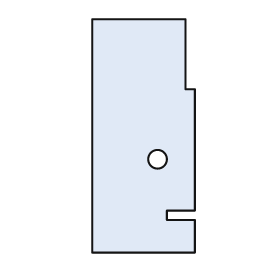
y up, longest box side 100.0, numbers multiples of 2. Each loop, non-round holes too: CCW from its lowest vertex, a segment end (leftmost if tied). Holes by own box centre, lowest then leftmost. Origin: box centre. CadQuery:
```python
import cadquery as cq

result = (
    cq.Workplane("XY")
    .moveTo(-22.0, -50.0)
    .lineTo(22.0, -50.0)
    .lineTo(22.0, -36.0)
    .lineTo(10.0, -36.0)
    .lineTo(10.0, -32.0)
    .lineTo(22.0, -32.0)
    .lineTo(22.0, 20.0)
    .lineTo(18.0, 20.0)
    .lineTo(18.0, 50.0)
    .lineTo(-22.0, 50.0)
    .close()
    .moveTo(6.0, -10.0)
    .circle(4.0)
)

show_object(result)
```